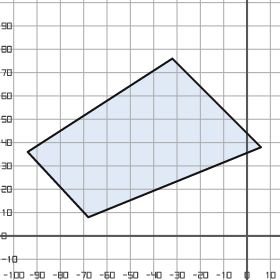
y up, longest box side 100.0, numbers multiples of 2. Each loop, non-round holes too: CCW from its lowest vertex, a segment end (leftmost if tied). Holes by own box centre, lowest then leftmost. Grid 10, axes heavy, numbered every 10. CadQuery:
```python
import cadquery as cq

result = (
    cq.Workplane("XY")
    .moveTo(-68.0, 8.0)
    .lineTo(6.0, 38.0)
    .lineTo(-32.0, 76.0)
    .lineTo(-94.0, 36.0)
    .close()
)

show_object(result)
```